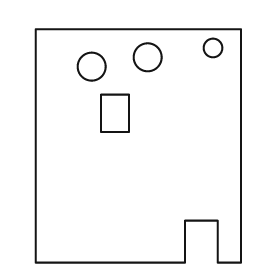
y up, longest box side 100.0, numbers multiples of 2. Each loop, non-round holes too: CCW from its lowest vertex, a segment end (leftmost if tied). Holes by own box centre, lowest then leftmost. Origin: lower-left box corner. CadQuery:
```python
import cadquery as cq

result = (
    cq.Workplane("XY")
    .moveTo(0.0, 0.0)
    .lineTo(64.0, 0.0)
    .lineTo(64.0, 18.0)
    .lineTo(78.0, 18.0)
    .lineTo(78.0, 0.0)
    .lineTo(88.0, 0.0)
    .lineTo(88.0, 100.0)
    .lineTo(0.0, 100.0)
    .close()
    .moveTo(28.0, 56.0)
    .lineTo(40.0, 56.0)
    .lineTo(40.0, 72.0)
    .lineTo(28.0, 72.0)
    .close()
    .moveTo(24.0, 84.0)
    .circle(6.0)
    .moveTo(48.0, 88.0)
    .circle(6.0)
    .moveTo(76.0, 92.0)
    .circle(4.0)
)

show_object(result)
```